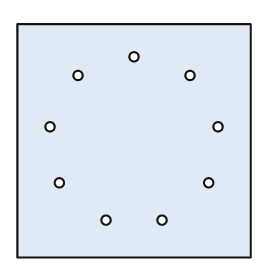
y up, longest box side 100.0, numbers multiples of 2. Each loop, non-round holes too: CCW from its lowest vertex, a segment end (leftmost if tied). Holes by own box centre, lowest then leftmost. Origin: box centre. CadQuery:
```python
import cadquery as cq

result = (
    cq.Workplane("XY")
    .moveTo(-50.0, -50.0)
    .lineTo(50.0, -50.0)
    .lineTo(50.0, 50.0)
    .lineTo(-50.0, 50.0)
    .close()
    .moveTo(-12.0, -34.0)
    .circle(2.0)
    .moveTo(12.0, -34.0)
    .circle(2.0)
    .moveTo(-32.0, -18.0)
    .circle(2.0)
    .moveTo(32.0, -18.0)
    .circle(2.0)
    .moveTo(-36.0, 6.0)
    .circle(2.0)
    .moveTo(36.0, 6.0)
    .circle(2.0)
    .moveTo(-24.0, 28.0)
    .circle(2.0)
    .moveTo(24.0, 28.0)
    .circle(2.0)
    .moveTo(0.0, 36.0)
    .circle(2.0)
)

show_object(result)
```